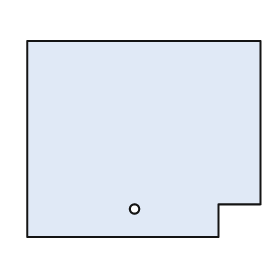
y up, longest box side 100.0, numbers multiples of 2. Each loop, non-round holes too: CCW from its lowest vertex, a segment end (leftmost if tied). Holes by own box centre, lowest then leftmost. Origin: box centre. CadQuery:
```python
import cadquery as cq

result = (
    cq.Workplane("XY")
    .moveTo(-50.0, -42.0)
    .lineTo(32.0, -42.0)
    .lineTo(32.0, -28.0)
    .lineTo(50.0, -28.0)
    .lineTo(50.0, 42.0)
    .lineTo(-50.0, 42.0)
    .close()
    .moveTo(-4.0, -30.0)
    .circle(2.0)
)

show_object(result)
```